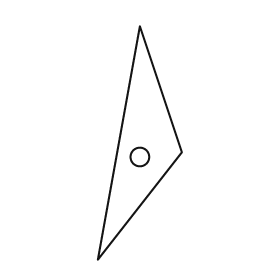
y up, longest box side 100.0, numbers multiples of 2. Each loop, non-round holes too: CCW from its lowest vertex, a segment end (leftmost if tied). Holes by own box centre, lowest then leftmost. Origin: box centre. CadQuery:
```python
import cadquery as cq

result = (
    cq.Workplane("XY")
    .moveTo(-18.0, -50.0)
    .lineTo(18.0, -4.0)
    .lineTo(0.0, 50.0)
    .close()
    .moveTo(0.0, -6.0)
    .circle(4.0)
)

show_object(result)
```